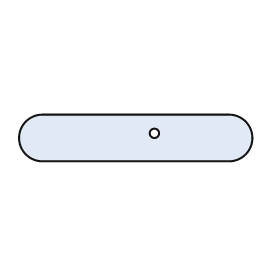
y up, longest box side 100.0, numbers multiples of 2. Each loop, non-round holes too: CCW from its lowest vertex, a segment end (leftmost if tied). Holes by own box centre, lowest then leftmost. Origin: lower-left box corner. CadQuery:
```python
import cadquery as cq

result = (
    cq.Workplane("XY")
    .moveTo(10.0, 0.0)
    .lineTo(90.0, 0.0)
    .threePointArc((100.0, 10.0), (90.0, 20.0))
    .lineTo(10.0, 20.0)
    .threePointArc((0.0, 10.0), (10.0, 0.0))
    .close()
    .moveTo(58.0, 12.0)
    .circle(2.0)
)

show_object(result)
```